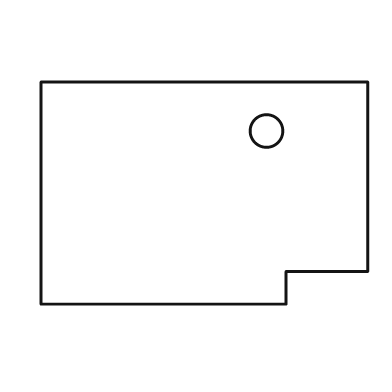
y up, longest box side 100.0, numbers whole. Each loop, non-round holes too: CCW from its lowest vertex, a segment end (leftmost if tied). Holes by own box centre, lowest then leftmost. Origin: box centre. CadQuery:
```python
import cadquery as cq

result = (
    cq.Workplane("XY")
    .moveTo(-50.0, -34.0)
    .lineTo(25.0, -34.0)
    .lineTo(25.0, -24.0)
    .lineTo(50.0, -24.0)
    .lineTo(50.0, 34.0)
    .lineTo(-50.0, 34.0)
    .close()
    .moveTo(19.0, 19.0)
    .circle(5.0)
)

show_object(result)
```